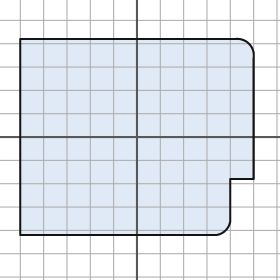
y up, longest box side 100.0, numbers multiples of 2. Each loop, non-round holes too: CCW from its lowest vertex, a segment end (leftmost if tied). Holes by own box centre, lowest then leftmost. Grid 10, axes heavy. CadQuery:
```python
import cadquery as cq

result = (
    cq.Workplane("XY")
    .moveTo(-50.0, -42.0)
    .lineTo(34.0, -42.0)
    .threePointArc((38.0, -40.0), (40.0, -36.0))
    .lineTo(40.0, -18.0)
    .lineTo(50.0, -18.0)
    .lineTo(50.0, 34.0)
    .threePointArc((48.0, 40.0), (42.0, 42.0))
    .lineTo(-50.0, 42.0)
    .close()
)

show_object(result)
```